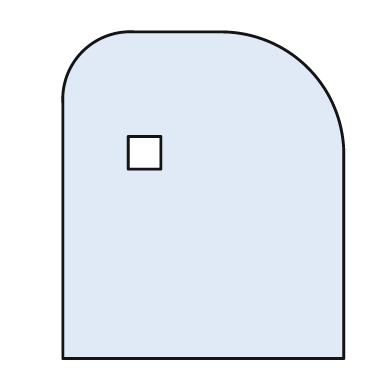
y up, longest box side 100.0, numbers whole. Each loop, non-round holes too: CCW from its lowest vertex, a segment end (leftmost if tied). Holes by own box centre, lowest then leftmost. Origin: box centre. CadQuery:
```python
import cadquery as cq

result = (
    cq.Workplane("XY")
    .moveTo(-43.0, -50.0)
    .lineTo(43.0, -50.0)
    .lineTo(43.0, 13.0)
    .threePointArc((32.0, 39.0), (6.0, 50.0))
    .lineTo(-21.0, 50.0)
    .threePointArc((-37.0, 44.0), (-43.0, 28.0))
    .close()
    .moveTo(-23.0, 8.0)
    .lineTo(-13.0, 8.0)
    .lineTo(-13.0, 18.0)
    .lineTo(-23.0, 18.0)
    .close()
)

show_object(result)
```